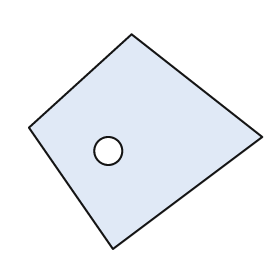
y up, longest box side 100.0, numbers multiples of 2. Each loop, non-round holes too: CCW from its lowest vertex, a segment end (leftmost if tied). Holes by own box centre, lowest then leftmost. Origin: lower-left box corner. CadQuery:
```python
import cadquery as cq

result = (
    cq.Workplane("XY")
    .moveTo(36.0, 0.0)
    .lineTo(100.0, 48.0)
    .lineTo(44.0, 92.0)
    .lineTo(0.0, 52.0)
    .close()
    .moveTo(34.0, 42.0)
    .circle(6.0)
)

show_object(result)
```